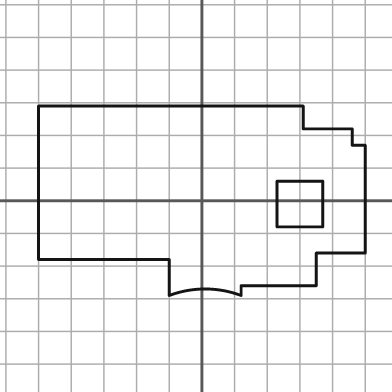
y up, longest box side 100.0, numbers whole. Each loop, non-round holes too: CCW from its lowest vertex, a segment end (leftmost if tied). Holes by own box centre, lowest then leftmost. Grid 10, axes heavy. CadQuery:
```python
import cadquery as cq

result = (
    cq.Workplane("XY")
    .moveTo(-10.0, -29.0)
    .threePointArc((1.0, -27.0), (12.0, -29.0))
    .lineTo(12.0, -26.0)
    .lineTo(35.0, -26.0)
    .lineTo(35.0, -16.0)
    .lineTo(50.0, -16.0)
    .lineTo(50.0, 17.0)
    .lineTo(46.0, 17.0)
    .lineTo(46.0, 22.0)
    .lineTo(31.0, 22.0)
    .lineTo(31.0, 29.0)
    .lineTo(-50.0, 29.0)
    .lineTo(-50.0, -18.0)
    .lineTo(-10.0, -18.0)
    .close()
    .moveTo(23.0, -8.0)
    .lineTo(37.0, -8.0)
    .lineTo(37.0, 6.0)
    .lineTo(23.0, 6.0)
    .close()
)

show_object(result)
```